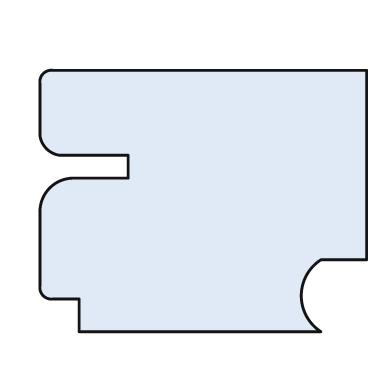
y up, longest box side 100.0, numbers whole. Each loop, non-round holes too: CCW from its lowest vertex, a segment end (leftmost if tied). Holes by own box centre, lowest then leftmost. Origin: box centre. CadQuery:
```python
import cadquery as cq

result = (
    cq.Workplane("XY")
    .moveTo(-38.0, -40.0)
    .lineTo(36.0, -40.0)
    .threePointArc((30.0, -29.0), (36.0, -18.0))
    .lineTo(50.0, -18.0)
    .lineTo(50.0, 40.0)
    .lineTo(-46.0, 40.0)
    .threePointArc((-49.0, 39.0), (-50.0, 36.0))
    .lineTo(-50.0, 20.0)
    .threePointArc((-48.0, 16.0), (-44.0, 14.0))
    .lineTo(-23.0, 14.0)
    .lineTo(-23.0, 7.0)
    .lineTo(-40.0, 7.0)
    .threePointArc((-47.0, 4.0), (-50.0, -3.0))
    .lineTo(-50.0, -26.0)
    .threePointArc((-49.0, -29.0), (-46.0, -30.0))
    .lineTo(-38.0, -30.0)
    .close()
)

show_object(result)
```